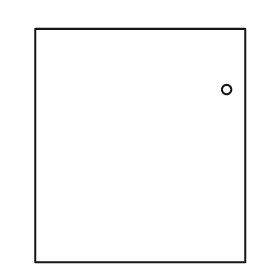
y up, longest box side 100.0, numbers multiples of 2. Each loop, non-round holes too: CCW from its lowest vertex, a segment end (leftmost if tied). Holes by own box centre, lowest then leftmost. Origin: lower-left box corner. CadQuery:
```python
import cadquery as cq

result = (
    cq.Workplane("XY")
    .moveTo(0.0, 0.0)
    .lineTo(90.0, 0.0)
    .lineTo(90.0, 100.0)
    .lineTo(0.0, 100.0)
    .close()
    .moveTo(82.0, 74.0)
    .circle(2.0)
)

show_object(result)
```